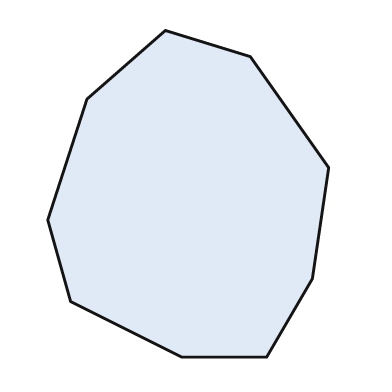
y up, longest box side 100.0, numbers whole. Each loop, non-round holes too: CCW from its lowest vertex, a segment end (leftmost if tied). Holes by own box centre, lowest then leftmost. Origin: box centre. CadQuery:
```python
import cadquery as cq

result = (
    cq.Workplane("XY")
    .moveTo(-2.0, -50.0)
    .lineTo(24.0, -50.0)
    .lineTo(38.0, -26.0)
    .lineTo(43.0, 8.0)
    .lineTo(19.0, 42.0)
    .lineTo(-7.0, 50.0)
    .lineTo(-31.0, 29.0)
    .lineTo(-43.0, -8.0)
    .lineTo(-36.0, -33.0)
    .close()
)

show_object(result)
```